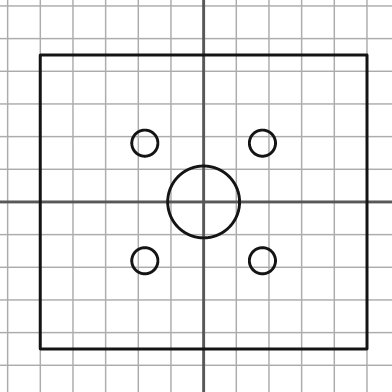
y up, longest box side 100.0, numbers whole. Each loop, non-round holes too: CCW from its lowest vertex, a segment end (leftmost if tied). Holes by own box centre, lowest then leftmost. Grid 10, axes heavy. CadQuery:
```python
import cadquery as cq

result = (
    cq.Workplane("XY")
    .moveTo(-50.0, -45.0)
    .lineTo(50.0, -45.0)
    .lineTo(50.0, 45.0)
    .lineTo(-50.0, 45.0)
    .close()
    .moveTo(-18.0, -18.0)
    .circle(4.0)
    .moveTo(18.0, -18.0)
    .circle(4.0)
    .moveTo(0.0, 0.0)
    .circle(11.0)
    .moveTo(-18.0, 18.0)
    .circle(4.0)
    .moveTo(18.0, 18.0)
    .circle(4.0)
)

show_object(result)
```